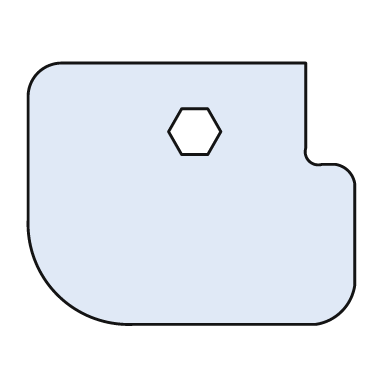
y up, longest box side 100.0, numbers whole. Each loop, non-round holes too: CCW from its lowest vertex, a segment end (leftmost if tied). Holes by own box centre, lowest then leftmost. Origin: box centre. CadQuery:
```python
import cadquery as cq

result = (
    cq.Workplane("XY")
    .moveTo(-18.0, -40.0)
    .lineTo(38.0, -40.0)
    .threePointArc((46.0, -36.0), (50.0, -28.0))
    .lineTo(50.0, 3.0)
    .threePointArc((48.0, 7.0), (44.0, 9.0))
    .lineTo(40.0, 9.0)
    .threePointArc((36.0, 10.0), (35.0, 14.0))
    .lineTo(35.0, 40.0)
    .lineTo(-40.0, 40.0)
    .threePointArc((-47.0, 37.0), (-50.0, 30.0))
    .lineTo(-50.0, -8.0)
    .threePointArc((-41.0, -31.0), (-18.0, -40.0))
    .close()
    .moveTo(-3.0, 12.0)
    .lineTo(5.0, 12.0)
    .lineTo(9.0, 19.0)
    .lineTo(5.0, 26.0)
    .lineTo(-3.0, 26.0)
    .lineTo(-7.0, 19.0)
    .close()
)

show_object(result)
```